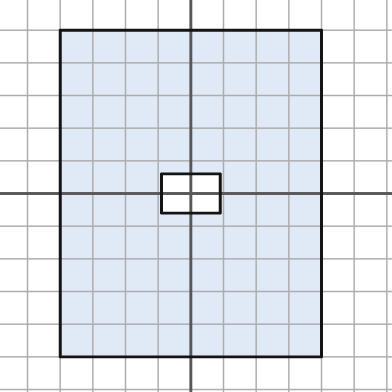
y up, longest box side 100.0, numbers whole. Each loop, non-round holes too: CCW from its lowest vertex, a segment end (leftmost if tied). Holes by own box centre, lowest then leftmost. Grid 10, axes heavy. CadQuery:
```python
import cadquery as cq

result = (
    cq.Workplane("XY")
    .moveTo(-40.0, -50.0)
    .lineTo(40.0, -50.0)
    .lineTo(40.0, 50.0)
    .lineTo(-40.0, 50.0)
    .close()
    .moveTo(-9.0, -6.0)
    .lineTo(9.0, -6.0)
    .lineTo(9.0, 6.0)
    .lineTo(-9.0, 6.0)
    .close()
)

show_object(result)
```